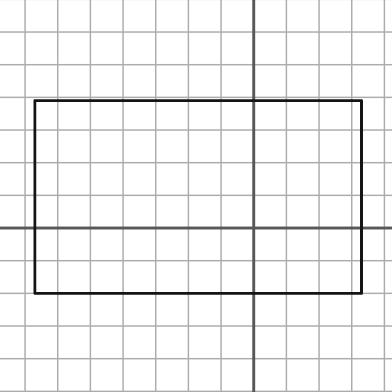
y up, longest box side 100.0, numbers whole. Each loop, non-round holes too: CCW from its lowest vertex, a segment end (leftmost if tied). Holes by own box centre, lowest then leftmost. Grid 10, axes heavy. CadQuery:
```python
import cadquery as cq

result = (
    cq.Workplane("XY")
    .moveTo(-67.0, -20.0)
    .lineTo(33.0, -20.0)
    .lineTo(33.0, 39.0)
    .lineTo(-67.0, 39.0)
    .close()
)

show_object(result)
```